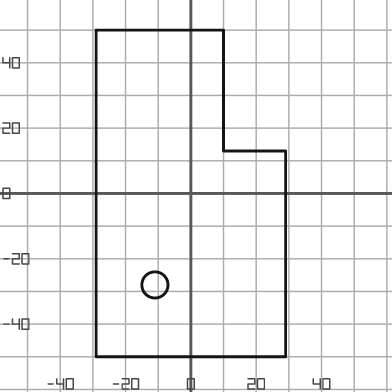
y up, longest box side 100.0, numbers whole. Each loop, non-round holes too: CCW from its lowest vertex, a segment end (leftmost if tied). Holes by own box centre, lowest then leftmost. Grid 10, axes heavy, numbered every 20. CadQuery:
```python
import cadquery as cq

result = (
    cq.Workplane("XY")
    .moveTo(-29.0, -50.0)
    .lineTo(29.0, -50.0)
    .lineTo(29.0, 13.0)
    .lineTo(10.0, 13.0)
    .lineTo(10.0, 50.0)
    .lineTo(-29.0, 50.0)
    .close()
    .moveTo(-11.0, -28.0)
    .circle(4.0)
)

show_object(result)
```